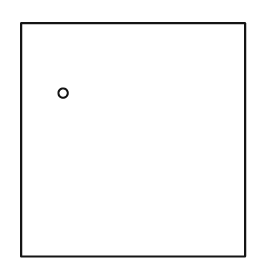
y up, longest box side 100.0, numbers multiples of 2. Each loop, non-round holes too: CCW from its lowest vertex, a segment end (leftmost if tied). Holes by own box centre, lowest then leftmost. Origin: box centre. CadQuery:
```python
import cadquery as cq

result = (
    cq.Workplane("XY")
    .moveTo(-48.0, -50.0)
    .lineTo(48.0, -50.0)
    .lineTo(48.0, 50.0)
    .lineTo(-48.0, 50.0)
    .close()
    .moveTo(-30.0, 20.0)
    .circle(2.0)
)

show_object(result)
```